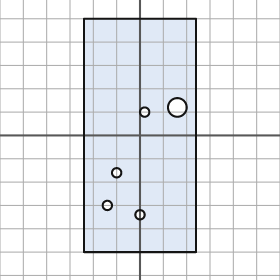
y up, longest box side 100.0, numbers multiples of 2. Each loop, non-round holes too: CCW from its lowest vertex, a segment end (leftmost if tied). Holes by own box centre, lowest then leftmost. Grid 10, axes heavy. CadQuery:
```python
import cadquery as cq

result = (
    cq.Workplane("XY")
    .moveTo(-24.0, -50.0)
    .lineTo(24.0, -50.0)
    .lineTo(24.0, 50.0)
    .lineTo(-24.0, 50.0)
    .close()
    .moveTo(0.0, -34.0)
    .circle(2.0)
    .moveTo(-14.0, -30.0)
    .circle(2.0)
    .moveTo(-10.0, -16.0)
    .circle(2.0)
    .moveTo(2.0, 10.0)
    .circle(2.0)
    .moveTo(16.0, 12.0)
    .circle(4.0)
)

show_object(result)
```